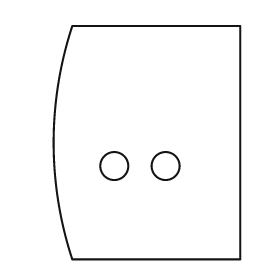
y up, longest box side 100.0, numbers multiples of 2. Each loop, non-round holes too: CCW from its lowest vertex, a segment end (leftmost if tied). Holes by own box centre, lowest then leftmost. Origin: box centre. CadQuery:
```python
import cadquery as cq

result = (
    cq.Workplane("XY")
    .moveTo(-32.0, -50.0)
    .lineTo(40.0, -50.0)
    .lineTo(40.0, 50.0)
    .lineTo(-32.0, 50.0)
    .threePointArc((-40.0, 0.0), (-32.0, -50.0))
    .close()
    .moveTo(-14.0, -10.0)
    .circle(6.0)
    .moveTo(8.0, -10.0)
    .circle(6.0)
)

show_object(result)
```